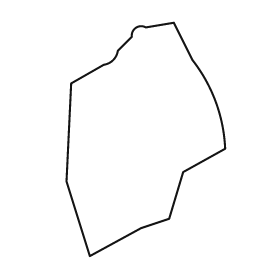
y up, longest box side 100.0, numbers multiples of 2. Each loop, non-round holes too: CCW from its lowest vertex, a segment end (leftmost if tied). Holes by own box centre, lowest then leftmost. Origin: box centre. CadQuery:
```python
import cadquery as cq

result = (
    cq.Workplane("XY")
    .moveTo(-24.0, -50.0)
    .lineTo(-2.0, -38.0)
    .lineTo(10.0, -34.0)
    .lineTo(16.0, -14.0)
    .lineTo(34.0, -4.0)
    .threePointArc((30.0, 16.0), (20.0, 34.0))
    .lineTo(12.0, 50.0)
    .lineTo(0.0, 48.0)
    .threePointArc((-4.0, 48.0), (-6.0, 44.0))
    .lineTo(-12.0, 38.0)
    .threePointArc((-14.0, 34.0), (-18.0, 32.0))
    .lineTo(-32.0, 24.0)
    .lineTo(-34.0, -18.0)
    .close()
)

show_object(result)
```